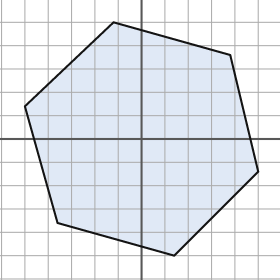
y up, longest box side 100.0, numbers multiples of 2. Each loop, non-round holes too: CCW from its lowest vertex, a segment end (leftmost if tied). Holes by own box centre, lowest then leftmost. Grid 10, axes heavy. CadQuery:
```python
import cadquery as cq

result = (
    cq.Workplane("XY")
    .moveTo(14.0, -50.0)
    .lineTo(50.0, -14.0)
    .lineTo(38.0, 36.0)
    .lineTo(-12.0, 50.0)
    .lineTo(-50.0, 14.0)
    .lineTo(-36.0, -36.0)
    .close()
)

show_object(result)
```